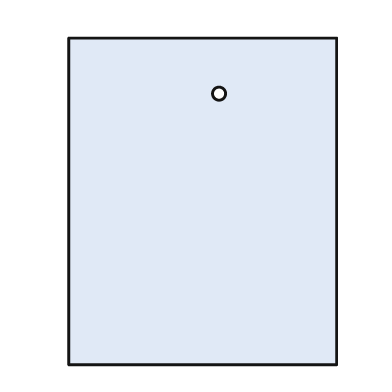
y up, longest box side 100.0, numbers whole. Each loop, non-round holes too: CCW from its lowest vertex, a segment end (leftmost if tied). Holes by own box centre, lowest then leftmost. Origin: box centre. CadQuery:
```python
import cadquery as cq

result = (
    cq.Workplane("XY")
    .moveTo(-41.0, -50.0)
    .lineTo(41.0, -50.0)
    .lineTo(41.0, 50.0)
    .lineTo(-41.0, 50.0)
    .close()
    .moveTo(5.0, 33.0)
    .circle(2.0)
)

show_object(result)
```